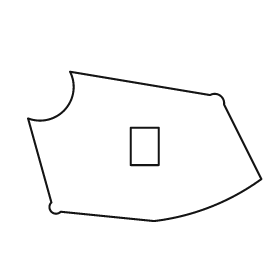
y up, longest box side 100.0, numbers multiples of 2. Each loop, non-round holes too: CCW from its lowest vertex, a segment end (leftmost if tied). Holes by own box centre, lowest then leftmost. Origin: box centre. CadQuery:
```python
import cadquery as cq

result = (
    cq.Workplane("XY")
    .moveTo(4.0, -32.0)
    .threePointArc((28.0, -26.0), (50.0, -14.0))
    .lineTo(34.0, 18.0)
    .threePointArc((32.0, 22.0), (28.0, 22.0))
    .lineTo(-32.0, 32.0)
    .threePointArc((-34.0, 16.0), (-50.0, 12.0))
    .lineTo(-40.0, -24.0)
    .threePointArc((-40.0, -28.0), (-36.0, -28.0))
    .close()
    .moveTo(-6.0, -8.0)
    .lineTo(6.0, -8.0)
    .lineTo(6.0, 8.0)
    .lineTo(-6.0, 8.0)
    .close()
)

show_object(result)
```